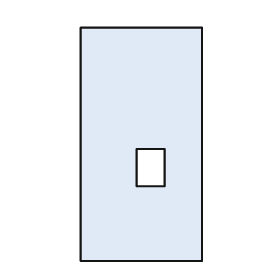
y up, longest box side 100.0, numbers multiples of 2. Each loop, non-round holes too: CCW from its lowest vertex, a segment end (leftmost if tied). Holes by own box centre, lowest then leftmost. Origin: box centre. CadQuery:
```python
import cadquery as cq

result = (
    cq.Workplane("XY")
    .moveTo(-26.0, -50.0)
    .lineTo(26.0, -50.0)
    .lineTo(26.0, 50.0)
    .lineTo(-26.0, 50.0)
    .close()
    .moveTo(-2.0, -18.0)
    .lineTo(10.0, -18.0)
    .lineTo(10.0, -2.0)
    .lineTo(-2.0, -2.0)
    .close()
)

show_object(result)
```